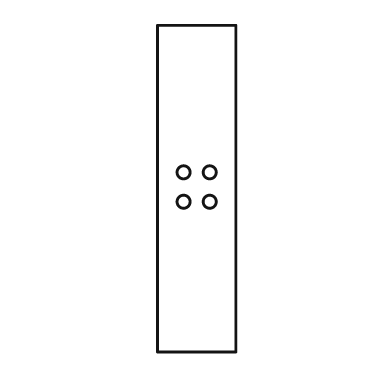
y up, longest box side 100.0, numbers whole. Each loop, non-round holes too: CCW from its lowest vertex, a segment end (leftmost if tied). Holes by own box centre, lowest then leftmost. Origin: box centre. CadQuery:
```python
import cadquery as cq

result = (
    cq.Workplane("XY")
    .moveTo(-12.0, -50.0)
    .lineTo(12.0, -50.0)
    .lineTo(12.0, 50.0)
    .lineTo(-12.0, 50.0)
    .close()
    .moveTo(-4.0, -4.0)
    .circle(2.0)
    .moveTo(4.0, -4.0)
    .circle(2.0)
    .moveTo(-4.0, 5.0)
    .circle(2.0)
    .moveTo(4.0, 5.0)
    .circle(2.0)
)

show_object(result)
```